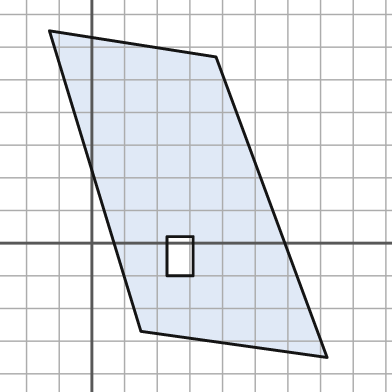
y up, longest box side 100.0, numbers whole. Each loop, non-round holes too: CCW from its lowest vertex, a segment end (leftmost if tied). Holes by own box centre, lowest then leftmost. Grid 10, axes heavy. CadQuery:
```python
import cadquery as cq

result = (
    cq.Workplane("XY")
    .moveTo(72.0, -35.0)
    .lineTo(38.0, 57.0)
    .lineTo(-13.0, 65.0)
    .lineTo(15.0, -27.0)
    .close()
    .moveTo(23.0, -10.0)
    .lineTo(31.0, -10.0)
    .lineTo(31.0, 2.0)
    .lineTo(23.0, 2.0)
    .close()
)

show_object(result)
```